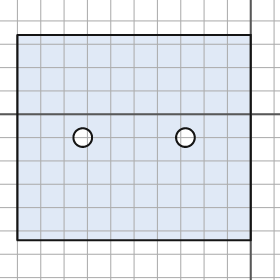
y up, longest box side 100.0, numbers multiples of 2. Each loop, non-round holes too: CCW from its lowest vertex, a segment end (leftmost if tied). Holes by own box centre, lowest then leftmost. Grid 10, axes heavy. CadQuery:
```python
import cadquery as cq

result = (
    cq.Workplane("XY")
    .moveTo(-100.0, -54.0)
    .lineTo(0.0, -54.0)
    .lineTo(0.0, 34.0)
    .lineTo(-100.0, 34.0)
    .close()
    .moveTo(-72.0, -10.0)
    .circle(4.0)
    .moveTo(-28.0, -10.0)
    .circle(4.0)
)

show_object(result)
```